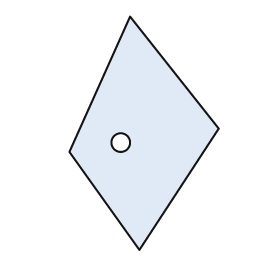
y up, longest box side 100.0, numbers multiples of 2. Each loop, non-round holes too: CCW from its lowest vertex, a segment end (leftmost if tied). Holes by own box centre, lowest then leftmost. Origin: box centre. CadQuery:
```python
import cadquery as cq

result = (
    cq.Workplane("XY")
    .moveTo(-2.0, -50.0)
    .lineTo(32.0, 2.0)
    .lineTo(-6.0, 50.0)
    .lineTo(-32.0, -8.0)
    .close()
    .moveTo(-10.0, -4.0)
    .circle(4.0)
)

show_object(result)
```